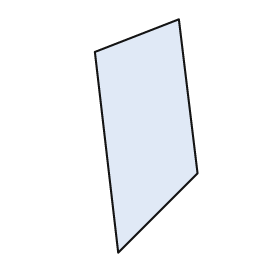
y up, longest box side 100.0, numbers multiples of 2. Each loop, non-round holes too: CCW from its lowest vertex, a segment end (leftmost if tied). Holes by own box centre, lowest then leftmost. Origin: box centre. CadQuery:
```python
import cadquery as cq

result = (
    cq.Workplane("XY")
    .moveTo(-12.0, -50.0)
    .lineTo(22.0, -16.0)
    .lineTo(14.0, 50.0)
    .lineTo(-22.0, 36.0)
    .close()
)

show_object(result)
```